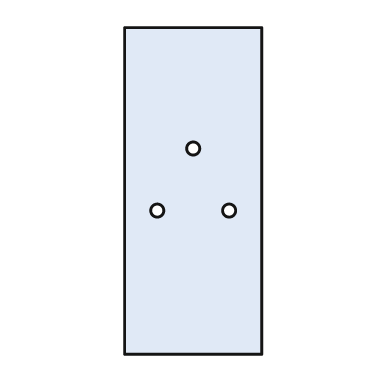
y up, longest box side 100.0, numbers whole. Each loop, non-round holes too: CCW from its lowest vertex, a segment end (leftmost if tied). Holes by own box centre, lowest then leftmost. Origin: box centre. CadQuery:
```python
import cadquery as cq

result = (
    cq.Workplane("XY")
    .moveTo(-21.0, -50.0)
    .lineTo(21.0, -50.0)
    .lineTo(21.0, 50.0)
    .lineTo(-21.0, 50.0)
    .close()
    .moveTo(-11.0, -6.0)
    .circle(2.0)
    .moveTo(11.0, -6.0)
    .circle(2.0)
    .moveTo(0.0, 13.0)
    .circle(2.0)
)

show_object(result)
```